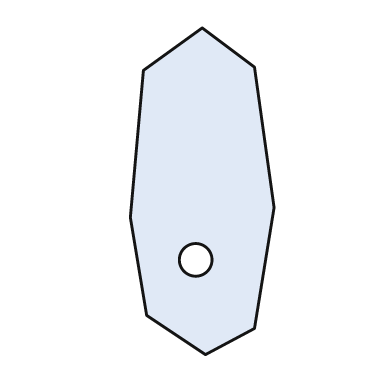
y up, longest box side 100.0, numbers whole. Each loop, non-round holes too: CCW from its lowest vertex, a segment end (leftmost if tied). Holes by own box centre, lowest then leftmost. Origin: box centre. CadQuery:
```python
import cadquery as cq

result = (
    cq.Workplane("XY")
    .moveTo(1.0, -50.0)
    .lineTo(16.0, -42.0)
    .lineTo(22.0, -5.0)
    .lineTo(16.0, 38.0)
    .lineTo(0.0, 50.0)
    .lineTo(-18.0, 37.0)
    .lineTo(-22.0, -8.0)
    .lineTo(-17.0, -38.0)
    .close()
    .moveTo(-2.0, -21.0)
    .circle(5.0)
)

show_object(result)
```